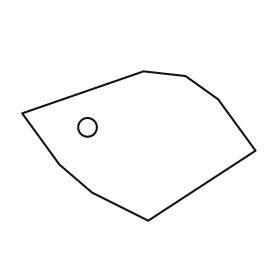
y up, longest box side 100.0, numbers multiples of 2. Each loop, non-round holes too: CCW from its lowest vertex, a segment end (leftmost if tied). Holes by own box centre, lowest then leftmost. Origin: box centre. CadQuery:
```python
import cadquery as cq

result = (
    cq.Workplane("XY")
    .moveTo(4.0, -32.0)
    .lineTo(50.0, -2.0)
    .lineTo(34.0, 20.0)
    .lineTo(20.0, 30.0)
    .lineTo(2.0, 32.0)
    .lineTo(-50.0, 14.0)
    .lineTo(-34.0, -8.0)
    .lineTo(-20.0, -20.0)
    .close()
    .moveTo(-22.0, 8.0)
    .circle(4.0)
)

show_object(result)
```